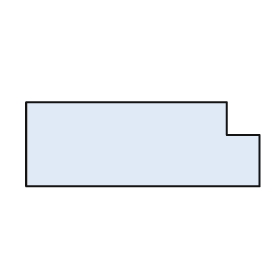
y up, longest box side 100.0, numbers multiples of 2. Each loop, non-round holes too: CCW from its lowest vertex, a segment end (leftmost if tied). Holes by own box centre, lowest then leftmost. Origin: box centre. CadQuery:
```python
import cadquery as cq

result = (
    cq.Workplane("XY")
    .moveTo(-50.0, -18.0)
    .lineTo(50.0, -18.0)
    .lineTo(50.0, 4.0)
    .lineTo(36.0, 4.0)
    .lineTo(36.0, 18.0)
    .lineTo(-50.0, 18.0)
    .close()
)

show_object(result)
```